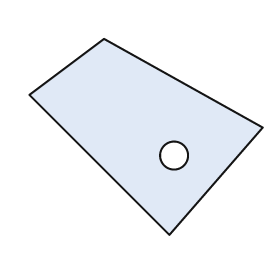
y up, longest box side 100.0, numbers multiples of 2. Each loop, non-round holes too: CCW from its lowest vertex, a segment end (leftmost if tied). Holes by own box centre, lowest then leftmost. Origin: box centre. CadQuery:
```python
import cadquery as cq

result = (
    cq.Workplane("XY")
    .moveTo(10.0, -42.0)
    .lineTo(50.0, 4.0)
    .lineTo(-18.0, 42.0)
    .lineTo(-50.0, 18.0)
    .close()
    .moveTo(12.0, -8.0)
    .circle(6.0)
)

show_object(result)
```